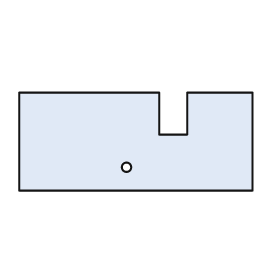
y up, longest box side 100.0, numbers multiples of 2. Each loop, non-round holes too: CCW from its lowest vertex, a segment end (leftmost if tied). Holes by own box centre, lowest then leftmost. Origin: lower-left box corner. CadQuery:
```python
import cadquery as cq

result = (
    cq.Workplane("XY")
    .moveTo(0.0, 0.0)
    .lineTo(100.0, 0.0)
    .lineTo(100.0, 42.0)
    .lineTo(72.0, 42.0)
    .lineTo(72.0, 24.0)
    .lineTo(60.0, 24.0)
    .lineTo(60.0, 42.0)
    .lineTo(0.0, 42.0)
    .close()
    .moveTo(46.0, 10.0)
    .circle(2.0)
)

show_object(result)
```